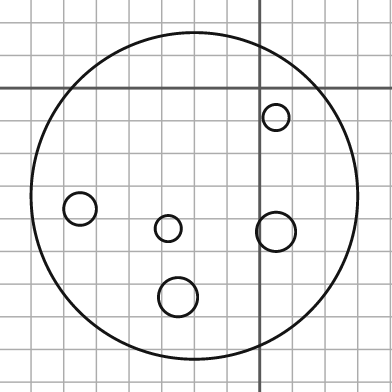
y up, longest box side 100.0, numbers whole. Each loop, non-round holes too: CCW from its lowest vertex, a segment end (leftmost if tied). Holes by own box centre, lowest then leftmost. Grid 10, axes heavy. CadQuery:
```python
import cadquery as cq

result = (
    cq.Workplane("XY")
    .moveTo(-20.0, -33.0)
    .circle(50.0)
    .moveTo(-25.0, -64.0)
    .circle(6.0)
    .moveTo(5.0, -44.0)
    .circle(6.0)
    .moveTo(-28.0, -43.0)
    .circle(4.0)
    .moveTo(-55.0, -37.0)
    .circle(5.0)
    .moveTo(5.0, -9.0)
    .circle(4.0)
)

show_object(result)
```